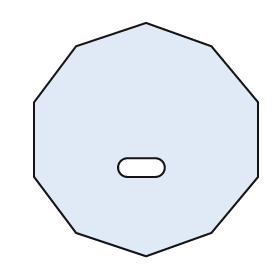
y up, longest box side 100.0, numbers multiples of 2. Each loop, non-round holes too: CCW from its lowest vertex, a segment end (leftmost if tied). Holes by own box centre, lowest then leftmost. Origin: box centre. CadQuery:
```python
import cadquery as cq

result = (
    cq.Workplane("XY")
    .moveTo(0.0, -50.0)
    .lineTo(28.0, -40.0)
    .lineTo(48.0, -16.0)
    .lineTo(48.0, 16.0)
    .lineTo(28.0, 40.0)
    .lineTo(0.0, 50.0)
    .lineTo(-30.0, 40.0)
    .lineTo(-48.0, 16.0)
    .lineTo(-48.0, -16.0)
    .lineTo(-30.0, -40.0)
    .close()
    .moveTo(-8.0, -16.0)
    .lineTo(4.0, -16.0)
    .threePointArc((8.0, -12.0), (4.0, -8.0))
    .lineTo(-8.0, -8.0)
    .threePointArc((-12.0, -12.0), (-8.0, -16.0))
    .close()
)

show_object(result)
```